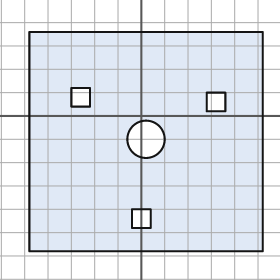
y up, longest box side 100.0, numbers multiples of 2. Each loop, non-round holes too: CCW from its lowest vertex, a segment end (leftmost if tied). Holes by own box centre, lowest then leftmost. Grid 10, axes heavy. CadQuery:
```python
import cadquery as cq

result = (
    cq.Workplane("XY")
    .moveTo(-48.0, -58.0)
    .lineTo(52.0, -58.0)
    .lineTo(52.0, 36.0)
    .lineTo(-48.0, 36.0)
    .close()
    .moveTo(-4.0, -48.0)
    .lineTo(4.0, -48.0)
    .lineTo(4.0, -40.0)
    .lineTo(-4.0, -40.0)
    .close()
    .moveTo(2.0, -10.0)
    .circle(8.0)
    .moveTo(28.0, 2.0)
    .lineTo(36.0, 2.0)
    .lineTo(36.0, 10.0)
    .lineTo(28.0, 10.0)
    .close()
    .moveTo(-30.0, 4.0)
    .lineTo(-22.0, 4.0)
    .lineTo(-22.0, 12.0)
    .lineTo(-30.0, 12.0)
    .close()
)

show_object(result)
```